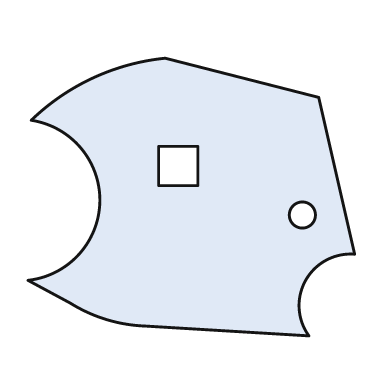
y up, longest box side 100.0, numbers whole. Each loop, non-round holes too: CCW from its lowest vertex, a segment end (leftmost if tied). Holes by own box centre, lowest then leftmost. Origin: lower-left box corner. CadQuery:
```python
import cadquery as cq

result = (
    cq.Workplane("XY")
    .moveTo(86.0, 0.0)
    .threePointArc((85.0, 17.0), (100.0, 25.0))
    .lineTo(89.0, 73.0)
    .lineTo(42.0, 85.0)
    .threePointArc((20.0, 79.0), (1.0, 66.0))
    .threePointArc((22.0, 41.0), (0.0, 17.0))
    .lineTo(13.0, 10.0)
    .threePointArc((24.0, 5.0), (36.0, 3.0))
    .close()
    .moveTo(84.0, 37.0)
    .circle(4.0)
    .moveTo(40.0, 46.0)
    .lineTo(52.0, 46.0)
    .lineTo(52.0, 58.0)
    .lineTo(40.0, 58.0)
    .close()
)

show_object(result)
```